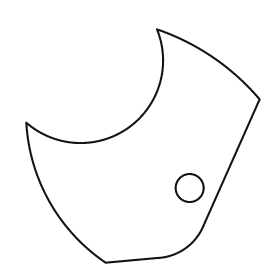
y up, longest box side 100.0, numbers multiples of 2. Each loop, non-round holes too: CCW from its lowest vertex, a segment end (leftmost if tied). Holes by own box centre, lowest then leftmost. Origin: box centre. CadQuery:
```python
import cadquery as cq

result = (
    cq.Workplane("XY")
    .moveTo(-16.0, -50.0)
    .lineTo(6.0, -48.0)
    .threePointArc((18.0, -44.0), (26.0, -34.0))
    .lineTo(50.0, 20.0)
    .threePointArc((30.0, 38.0), (6.0, 50.0))
    .threePointArc((-6.0, 8.0), (-50.0, 10.0))
    .threePointArc((-40.0, -24.0), (-16.0, -50.0))
    .close()
    .moveTo(20.0, -18.0)
    .circle(6.0)
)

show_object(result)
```